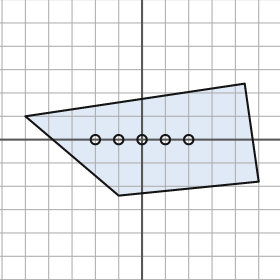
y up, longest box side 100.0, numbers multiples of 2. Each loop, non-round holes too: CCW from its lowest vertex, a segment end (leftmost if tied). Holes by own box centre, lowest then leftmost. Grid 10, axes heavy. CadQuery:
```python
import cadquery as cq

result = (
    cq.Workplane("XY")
    .moveTo(-10.0, -24.0)
    .lineTo(50.0, -18.0)
    .lineTo(44.0, 24.0)
    .lineTo(-50.0, 10.0)
    .close()
    .moveTo(-20.0, 0.0)
    .circle(2.0)
    .moveTo(-10.0, 0.0)
    .circle(2.0)
    .moveTo(0.0, 0.0)
    .circle(2.0)
    .moveTo(10.0, 0.0)
    .circle(2.0)
    .moveTo(20.0, 0.0)
    .circle(2.0)
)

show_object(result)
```